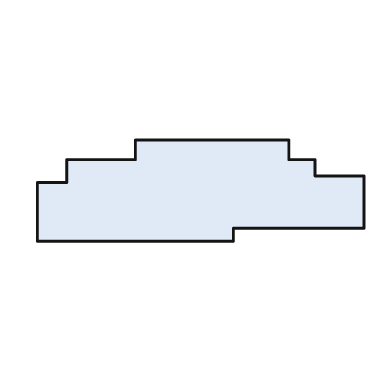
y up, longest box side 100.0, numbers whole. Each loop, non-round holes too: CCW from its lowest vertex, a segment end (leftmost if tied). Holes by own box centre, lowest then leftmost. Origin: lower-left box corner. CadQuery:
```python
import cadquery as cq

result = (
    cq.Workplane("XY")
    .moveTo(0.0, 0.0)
    .lineTo(60.0, 0.0)
    .lineTo(60.0, 4.0)
    .lineTo(100.0, 4.0)
    .lineTo(100.0, 20.0)
    .lineTo(85.0, 20.0)
    .lineTo(85.0, 25.0)
    .lineTo(77.0, 25.0)
    .lineTo(77.0, 31.0)
    .lineTo(30.0, 31.0)
    .lineTo(30.0, 25.0)
    .lineTo(9.0, 25.0)
    .lineTo(9.0, 18.0)
    .lineTo(0.0, 18.0)
    .close()
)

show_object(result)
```